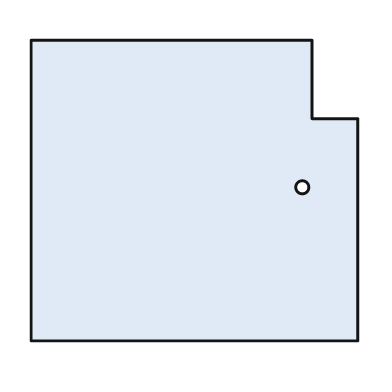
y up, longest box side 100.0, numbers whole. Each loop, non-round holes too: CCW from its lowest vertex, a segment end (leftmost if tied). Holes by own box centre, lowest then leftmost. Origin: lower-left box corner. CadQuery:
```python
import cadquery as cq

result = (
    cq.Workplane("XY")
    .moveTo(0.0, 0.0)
    .lineTo(100.0, 0.0)
    .lineTo(100.0, 68.0)
    .lineTo(86.0, 68.0)
    .lineTo(86.0, 92.0)
    .lineTo(0.0, 92.0)
    .close()
    .moveTo(83.0, 47.0)
    .circle(2.0)
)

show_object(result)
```